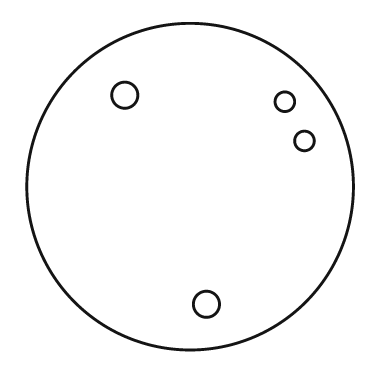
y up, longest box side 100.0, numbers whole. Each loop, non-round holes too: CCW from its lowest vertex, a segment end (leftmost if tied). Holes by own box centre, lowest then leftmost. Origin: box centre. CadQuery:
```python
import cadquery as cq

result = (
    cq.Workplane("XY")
    .moveTo(0.0, 0.0)
    .circle(50.0)
    .moveTo(5.0, -36.0)
    .circle(4.0)
    .moveTo(35.0, 14.0)
    .circle(3.0)
    .moveTo(29.0, 26.0)
    .circle(3.0)
    .moveTo(-20.0, 28.0)
    .circle(4.0)
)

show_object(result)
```